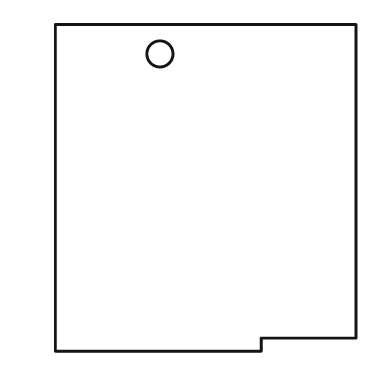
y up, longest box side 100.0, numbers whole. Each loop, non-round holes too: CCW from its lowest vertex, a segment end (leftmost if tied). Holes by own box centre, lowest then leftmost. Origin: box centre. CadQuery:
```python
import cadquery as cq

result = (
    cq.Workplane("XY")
    .moveTo(-46.0, -50.0)
    .lineTo(17.0, -50.0)
    .lineTo(17.0, -46.0)
    .lineTo(46.0, -46.0)
    .lineTo(46.0, 50.0)
    .lineTo(-46.0, 50.0)
    .close()
    .moveTo(-14.0, 41.0)
    .circle(4.0)
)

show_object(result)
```